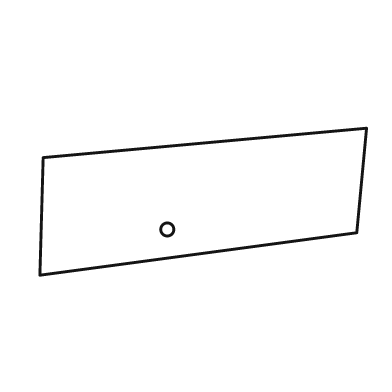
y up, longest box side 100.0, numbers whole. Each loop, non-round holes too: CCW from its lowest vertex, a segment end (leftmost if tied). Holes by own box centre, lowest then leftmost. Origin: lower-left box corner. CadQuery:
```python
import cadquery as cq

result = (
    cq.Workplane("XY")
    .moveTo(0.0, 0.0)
    .lineTo(97.0, 13.0)
    .lineTo(100.0, 45.0)
    .lineTo(1.0, 36.0)
    .close()
    .moveTo(39.0, 14.0)
    .circle(2.0)
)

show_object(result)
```